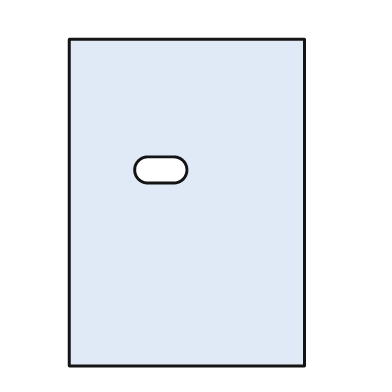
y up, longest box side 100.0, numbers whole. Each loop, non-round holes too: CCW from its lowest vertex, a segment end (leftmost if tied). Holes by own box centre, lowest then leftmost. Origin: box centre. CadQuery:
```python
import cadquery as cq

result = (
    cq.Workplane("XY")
    .moveTo(-36.0, -50.0)
    .lineTo(36.0, -50.0)
    .lineTo(36.0, 50.0)
    .lineTo(-36.0, 50.0)
    .close()
    .moveTo(-12.0, 6.0)
    .lineTo(-4.0, 6.0)
    .threePointArc((0.0, 10.0), (-4.0, 14.0))
    .lineTo(-12.0, 14.0)
    .threePointArc((-16.0, 10.0), (-12.0, 6.0))
    .close()
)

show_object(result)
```